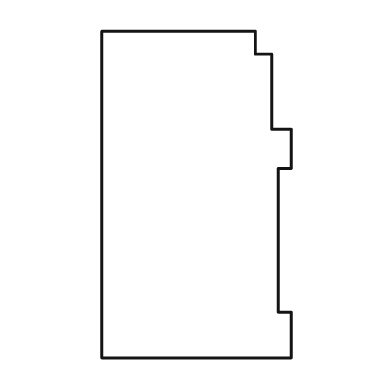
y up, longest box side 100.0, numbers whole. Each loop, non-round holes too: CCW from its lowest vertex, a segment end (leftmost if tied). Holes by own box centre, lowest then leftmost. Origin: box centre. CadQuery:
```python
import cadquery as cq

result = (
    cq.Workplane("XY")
    .moveTo(-29.0, -50.0)
    .lineTo(29.0, -50.0)
    .lineTo(29.0, -36.0)
    .lineTo(25.0, -36.0)
    .lineTo(25.0, 8.0)
    .lineTo(29.0, 8.0)
    .lineTo(29.0, 20.0)
    .lineTo(23.0, 20.0)
    .lineTo(23.0, 43.0)
    .lineTo(18.0, 43.0)
    .lineTo(18.0, 50.0)
    .lineTo(-29.0, 50.0)
    .close()
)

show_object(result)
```